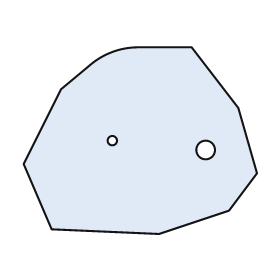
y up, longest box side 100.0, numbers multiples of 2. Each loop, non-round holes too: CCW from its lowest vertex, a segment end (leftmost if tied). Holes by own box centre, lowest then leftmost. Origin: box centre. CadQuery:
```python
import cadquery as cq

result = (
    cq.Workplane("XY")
    .moveTo(8.0, -40.0)
    .lineTo(38.0, -30.0)
    .lineTo(50.0, -14.0)
    .lineTo(42.0, 14.0)
    .lineTo(22.0, 40.0)
    .lineTo(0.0, 40.0)
    .threePointArc((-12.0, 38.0), (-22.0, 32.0))
    .lineTo(-34.0, 22.0)
    .lineTo(-50.0, -10.0)
    .lineTo(-38.0, -38.0)
    .close()
    .moveTo(28.0, -4.0)
    .circle(4.0)
    .moveTo(-12.0, 0.0)
    .circle(2.0)
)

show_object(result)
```